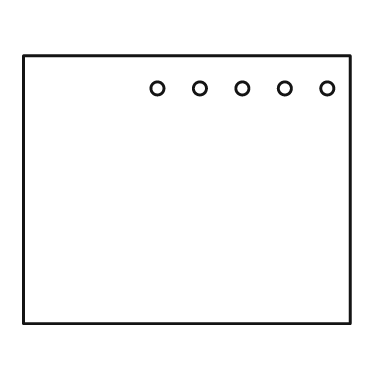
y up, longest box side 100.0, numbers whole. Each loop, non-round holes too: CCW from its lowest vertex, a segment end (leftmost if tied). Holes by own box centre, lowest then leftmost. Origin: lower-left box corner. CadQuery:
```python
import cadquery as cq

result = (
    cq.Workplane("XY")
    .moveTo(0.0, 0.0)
    .lineTo(100.0, 0.0)
    .lineTo(100.0, 82.0)
    .lineTo(0.0, 82.0)
    .close()
    .moveTo(41.0, 72.0)
    .circle(2.0)
    .moveTo(54.0, 72.0)
    .circle(2.0)
    .moveTo(67.0, 72.0)
    .circle(2.0)
    .moveTo(80.0, 72.0)
    .circle(2.0)
    .moveTo(93.0, 72.0)
    .circle(2.0)
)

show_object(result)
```